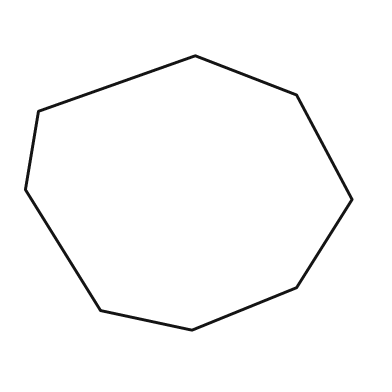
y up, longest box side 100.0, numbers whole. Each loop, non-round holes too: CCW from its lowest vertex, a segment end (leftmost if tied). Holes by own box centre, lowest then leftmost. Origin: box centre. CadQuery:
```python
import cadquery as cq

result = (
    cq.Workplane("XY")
    .moveTo(1.0, -42.0)
    .lineTo(33.0, -29.0)
    .lineTo(50.0, -2.0)
    .lineTo(33.0, 30.0)
    .lineTo(2.0, 42.0)
    .lineTo(-46.0, 25.0)
    .lineTo(-50.0, 1.0)
    .lineTo(-27.0, -36.0)
    .close()
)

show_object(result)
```